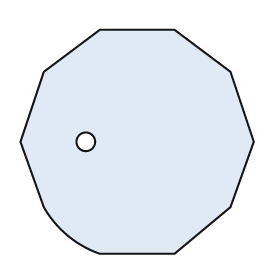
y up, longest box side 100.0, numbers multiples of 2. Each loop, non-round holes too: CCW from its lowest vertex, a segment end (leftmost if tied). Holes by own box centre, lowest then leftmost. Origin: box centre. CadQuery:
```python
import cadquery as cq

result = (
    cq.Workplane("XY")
    .moveTo(-16.0, -48.0)
    .lineTo(16.0, -48.0)
    .lineTo(40.0, -28.0)
    .lineTo(50.0, 0.0)
    .lineTo(40.0, 30.0)
    .lineTo(16.0, 48.0)
    .lineTo(-16.0, 48.0)
    .lineTo(-40.0, 30.0)
    .lineTo(-50.0, 0.0)
    .lineTo(-40.0, -28.0)
    .threePointArc((-30.0, -40.0), (-16.0, -48.0))
    .close()
    .moveTo(-22.0, 0.0)
    .circle(4.0)
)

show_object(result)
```